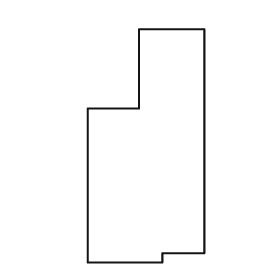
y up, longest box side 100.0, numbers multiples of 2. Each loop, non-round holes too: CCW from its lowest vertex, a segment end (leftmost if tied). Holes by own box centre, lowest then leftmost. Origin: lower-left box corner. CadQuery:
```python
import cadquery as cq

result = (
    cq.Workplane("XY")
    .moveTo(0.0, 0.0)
    .lineTo(32.0, 0.0)
    .lineTo(32.0, 4.0)
    .lineTo(50.0, 4.0)
    .lineTo(50.0, 100.0)
    .lineTo(22.0, 100.0)
    .lineTo(22.0, 66.0)
    .lineTo(0.0, 66.0)
    .close()
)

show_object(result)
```